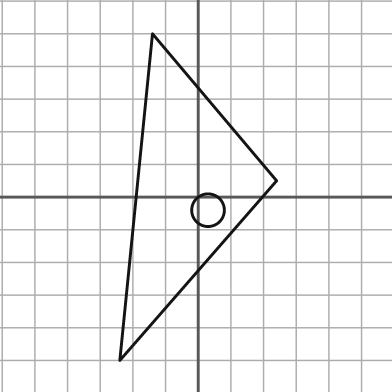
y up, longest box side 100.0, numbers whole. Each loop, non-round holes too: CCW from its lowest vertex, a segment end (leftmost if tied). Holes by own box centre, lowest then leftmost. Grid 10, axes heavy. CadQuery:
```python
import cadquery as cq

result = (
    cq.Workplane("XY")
    .moveTo(-24.0, -50.0)
    .lineTo(24.0, 5.0)
    .lineTo(-14.0, 50.0)
    .close()
    .moveTo(3.0, -4.0)
    .circle(5.0)
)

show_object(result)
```